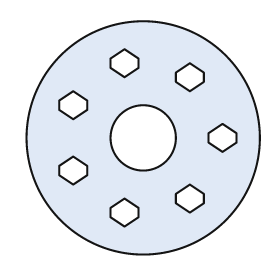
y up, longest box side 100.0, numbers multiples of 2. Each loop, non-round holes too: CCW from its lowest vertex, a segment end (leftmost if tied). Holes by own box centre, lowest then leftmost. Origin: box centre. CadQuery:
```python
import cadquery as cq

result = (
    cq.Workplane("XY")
    .moveTo(0.0, 0.0)
    .circle(50.0)
    .moveTo(-8.0, -38.0)
    .lineTo(-2.0, -34.0)
    .lineTo(-2.0, -30.0)
    .lineTo(-8.0, -26.0)
    .lineTo(-14.0, -30.0)
    .lineTo(-14.0, -34.0)
    .close()
    .moveTo(20.0, -32.0)
    .lineTo(26.0, -28.0)
    .lineTo(26.0, -24.0)
    .lineTo(20.0, -20.0)
    .lineTo(14.0, -24.0)
    .lineTo(14.0, -28.0)
    .close()
    .moveTo(-30.0, -20.0)
    .lineTo(-24.0, -16.0)
    .lineTo(-24.0, -12.0)
    .lineTo(-30.0, -8.0)
    .lineTo(-36.0, -12.0)
    .lineTo(-36.0, -16.0)
    .close()
    .moveTo(0.0, 0.0)
    .circle(14.0)
    .moveTo(34.0, -6.0)
    .lineTo(40.0, -2.0)
    .lineTo(40.0, 2.0)
    .lineTo(34.0, 6.0)
    .lineTo(28.0, 2.0)
    .lineTo(28.0, -2.0)
    .close()
    .moveTo(-30.0, 8.0)
    .lineTo(-24.0, 12.0)
    .lineTo(-24.0, 16.0)
    .lineTo(-30.0, 20.0)
    .lineTo(-36.0, 16.0)
    .lineTo(-36.0, 12.0)
    .close()
    .moveTo(20.0, 20.0)
    .lineTo(26.0, 24.0)
    .lineTo(26.0, 28.0)
    .lineTo(20.0, 32.0)
    .lineTo(14.0, 28.0)
    .lineTo(14.0, 24.0)
    .close()
    .moveTo(-8.0, 26.0)
    .lineTo(-2.0, 30.0)
    .lineTo(-2.0, 34.0)
    .lineTo(-8.0, 38.0)
    .lineTo(-14.0, 34.0)
    .lineTo(-14.0, 30.0)
    .close()
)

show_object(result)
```